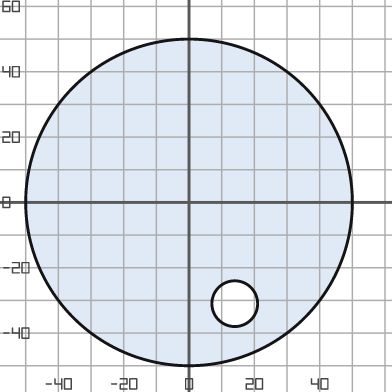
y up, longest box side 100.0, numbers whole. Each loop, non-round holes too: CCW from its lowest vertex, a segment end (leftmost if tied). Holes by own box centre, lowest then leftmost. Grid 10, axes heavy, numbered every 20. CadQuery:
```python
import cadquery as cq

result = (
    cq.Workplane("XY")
    .moveTo(0.0, 0.0)
    .circle(50.0)
    .moveTo(14.0, -31.0)
    .circle(7.0)
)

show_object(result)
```